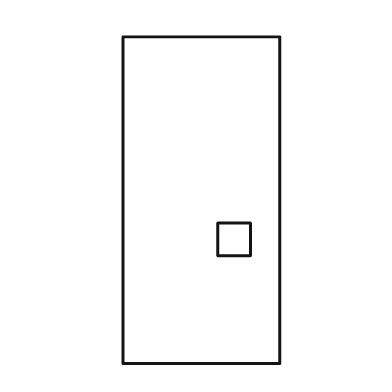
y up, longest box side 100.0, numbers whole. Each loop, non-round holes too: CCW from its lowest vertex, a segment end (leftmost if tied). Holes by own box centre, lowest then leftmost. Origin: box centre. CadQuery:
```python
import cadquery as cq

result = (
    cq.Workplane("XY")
    .moveTo(-24.0, -50.0)
    .lineTo(24.0, -50.0)
    .lineTo(24.0, 50.0)
    .lineTo(-24.0, 50.0)
    .close()
    .moveTo(5.0, -17.0)
    .lineTo(15.0, -17.0)
    .lineTo(15.0, -7.0)
    .lineTo(5.0, -7.0)
    .close()
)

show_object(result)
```